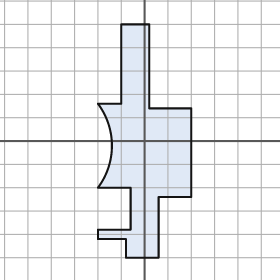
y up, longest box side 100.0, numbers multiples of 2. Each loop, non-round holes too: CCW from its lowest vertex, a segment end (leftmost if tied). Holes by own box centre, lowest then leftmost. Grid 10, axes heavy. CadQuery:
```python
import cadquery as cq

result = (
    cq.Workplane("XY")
    .moveTo(-8.0, -50.0)
    .lineTo(6.0, -50.0)
    .lineTo(6.0, -24.0)
    .lineTo(20.0, -24.0)
    .lineTo(20.0, 14.0)
    .lineTo(2.0, 14.0)
    .lineTo(2.0, 50.0)
    .lineTo(-10.0, 50.0)
    .lineTo(-10.0, 16.0)
    .lineTo(-20.0, 16.0)
    .threePointArc((-14.0, -2.0), (-20.0, -20.0))
    .lineTo(-6.0, -20.0)
    .lineTo(-6.0, -38.0)
    .lineTo(-20.0, -38.0)
    .lineTo(-20.0, -42.0)
    .lineTo(-8.0, -42.0)
    .close()
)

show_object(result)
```